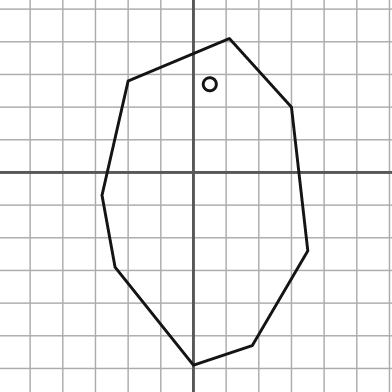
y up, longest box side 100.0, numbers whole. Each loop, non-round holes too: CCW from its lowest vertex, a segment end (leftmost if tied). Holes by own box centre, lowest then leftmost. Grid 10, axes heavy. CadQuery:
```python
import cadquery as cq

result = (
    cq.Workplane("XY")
    .moveTo(0.0, -59.0)
    .lineTo(18.0, -53.0)
    .lineTo(35.0, -24.0)
    .lineTo(30.0, 20.0)
    .lineTo(11.0, 41.0)
    .lineTo(-20.0, 28.0)
    .lineTo(-28.0, -7.0)
    .lineTo(-24.0, -29.0)
    .close()
    .moveTo(5.0, 27.0)
    .circle(2.0)
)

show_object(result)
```